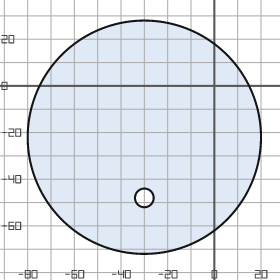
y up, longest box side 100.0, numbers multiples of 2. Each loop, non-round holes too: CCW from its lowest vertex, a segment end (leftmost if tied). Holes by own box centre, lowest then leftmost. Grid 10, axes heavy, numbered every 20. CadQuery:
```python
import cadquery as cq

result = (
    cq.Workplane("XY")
    .moveTo(-30.0, -22.0)
    .circle(50.0)
    .moveTo(-30.0, -48.0)
    .circle(4.0)
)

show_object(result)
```